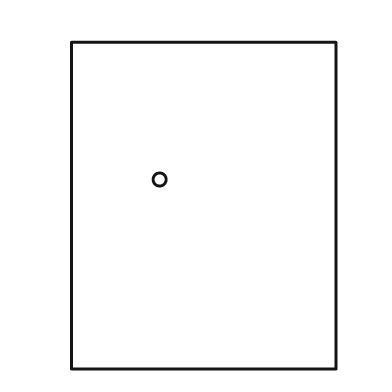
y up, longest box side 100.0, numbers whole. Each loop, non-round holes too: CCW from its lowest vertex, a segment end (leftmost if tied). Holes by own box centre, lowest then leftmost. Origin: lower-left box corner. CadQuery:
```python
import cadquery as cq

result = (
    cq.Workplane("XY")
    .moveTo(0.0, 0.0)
    .lineTo(81.0, 0.0)
    .lineTo(81.0, 100.0)
    .lineTo(0.0, 100.0)
    .close()
    .moveTo(27.0, 58.0)
    .circle(2.0)
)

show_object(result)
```